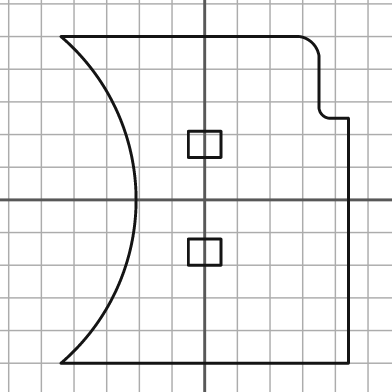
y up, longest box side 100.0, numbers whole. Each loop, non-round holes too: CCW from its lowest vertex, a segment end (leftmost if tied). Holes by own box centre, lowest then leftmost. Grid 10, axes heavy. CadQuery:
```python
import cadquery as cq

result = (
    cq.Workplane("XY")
    .moveTo(-44.0, -50.0)
    .lineTo(44.0, -50.0)
    .lineTo(44.0, 25.0)
    .lineTo(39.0, 25.0)
    .threePointArc((36.0, 26.0), (35.0, 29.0))
    .lineTo(35.0, 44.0)
    .threePointArc((33.0, 48.0), (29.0, 50.0))
    .lineTo(-44.0, 50.0)
    .threePointArc((-21.0, 0.0), (-44.0, -50.0))
    .close()
    .moveTo(-5.0, -20.0)
    .lineTo(5.0, -20.0)
    .lineTo(5.0, -12.0)
    .lineTo(-5.0, -12.0)
    .close()
    .moveTo(-5.0, 13.0)
    .lineTo(5.0, 13.0)
    .lineTo(5.0, 21.0)
    .lineTo(-5.0, 21.0)
    .close()
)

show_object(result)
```